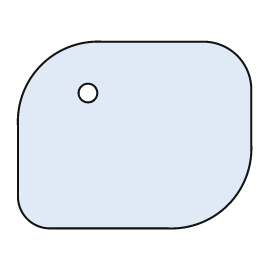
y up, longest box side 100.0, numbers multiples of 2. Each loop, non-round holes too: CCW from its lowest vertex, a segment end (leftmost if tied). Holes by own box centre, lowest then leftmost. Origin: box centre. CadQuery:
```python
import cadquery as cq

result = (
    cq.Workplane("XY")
    .moveTo(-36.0, -40.0)
    .lineTo(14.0, -40.0)
    .threePointArc((40.0, -30.0), (50.0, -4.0))
    .lineTo(50.0, 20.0)
    .threePointArc((44.0, 34.0), (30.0, 40.0))
    .lineTo(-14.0, 40.0)
    .threePointArc((-40.0, 30.0), (-50.0, 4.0))
    .lineTo(-50.0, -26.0)
    .threePointArc((-46.0, -36.0), (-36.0, -40.0))
    .close()
    .moveTo(-20.0, 18.0)
    .circle(4.0)
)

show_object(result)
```